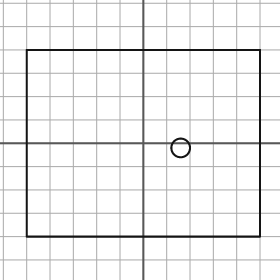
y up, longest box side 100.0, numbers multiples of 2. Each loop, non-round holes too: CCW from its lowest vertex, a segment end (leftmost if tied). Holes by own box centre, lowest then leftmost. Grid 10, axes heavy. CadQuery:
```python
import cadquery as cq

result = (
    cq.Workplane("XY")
    .moveTo(-50.0, -40.0)
    .lineTo(50.0, -40.0)
    .lineTo(50.0, 40.0)
    .lineTo(-50.0, 40.0)
    .close()
    .moveTo(16.0, -2.0)
    .circle(4.0)
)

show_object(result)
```